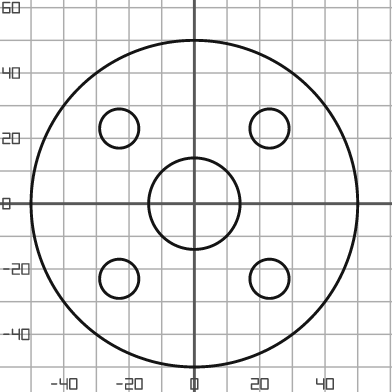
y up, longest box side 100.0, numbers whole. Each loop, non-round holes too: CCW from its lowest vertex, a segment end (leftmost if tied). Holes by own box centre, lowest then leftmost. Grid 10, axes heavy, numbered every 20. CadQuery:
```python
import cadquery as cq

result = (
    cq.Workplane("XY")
    .moveTo(0.0, 0.0)
    .circle(50.0)
    .moveTo(-23.0, -23.0)
    .circle(6.0)
    .moveTo(23.0, -23.0)
    .circle(6.0)
    .moveTo(0.0, 0.0)
    .circle(14.0)
    .moveTo(-23.0, 23.0)
    .circle(6.0)
    .moveTo(23.0, 23.0)
    .circle(6.0)
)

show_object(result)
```